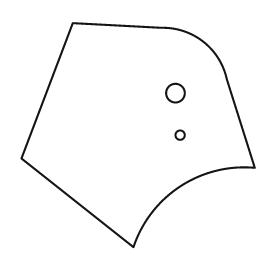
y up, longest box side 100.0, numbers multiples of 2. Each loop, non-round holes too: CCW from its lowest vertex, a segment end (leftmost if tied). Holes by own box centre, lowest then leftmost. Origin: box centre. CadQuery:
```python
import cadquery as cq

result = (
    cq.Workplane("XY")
    .moveTo(-2.0, -48.0)
    .threePointArc((18.0, -22.0), (50.0, -14.0))
    .lineTo(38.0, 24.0)
    .threePointArc((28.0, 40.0), (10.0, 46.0))
    .lineTo(-28.0, 48.0)
    .lineTo(-50.0, -10.0)
    .close()
    .moveTo(18.0, 0.0)
    .circle(2.0)
    .moveTo(16.0, 18.0)
    .circle(4.0)
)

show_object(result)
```